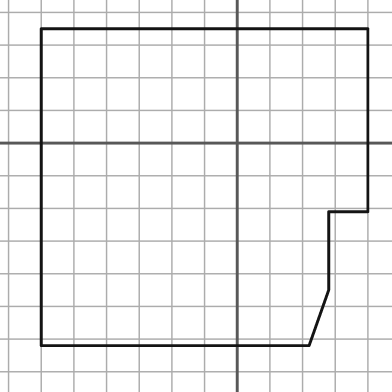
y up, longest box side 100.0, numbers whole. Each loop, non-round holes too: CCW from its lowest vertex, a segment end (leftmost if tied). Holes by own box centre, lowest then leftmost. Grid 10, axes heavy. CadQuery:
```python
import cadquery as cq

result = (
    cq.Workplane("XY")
    .moveTo(-60.0, -62.0)
    .lineTo(22.0, -62.0)
    .lineTo(28.0, -45.0)
    .lineTo(28.0, -21.0)
    .lineTo(40.0, -21.0)
    .lineTo(40.0, 35.0)
    .lineTo(-60.0, 35.0)
    .close()
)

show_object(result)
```